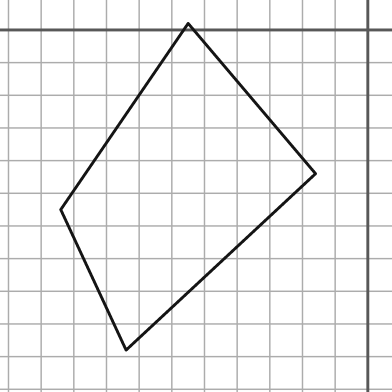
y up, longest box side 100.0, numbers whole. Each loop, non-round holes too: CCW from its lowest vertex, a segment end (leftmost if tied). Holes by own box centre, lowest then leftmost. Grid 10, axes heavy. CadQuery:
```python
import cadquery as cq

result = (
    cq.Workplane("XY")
    .moveTo(-74.0, -98.0)
    .lineTo(-16.0, -44.0)
    .lineTo(-55.0, 2.0)
    .lineTo(-94.0, -55.0)
    .close()
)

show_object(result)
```